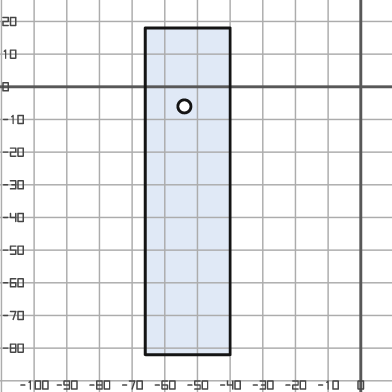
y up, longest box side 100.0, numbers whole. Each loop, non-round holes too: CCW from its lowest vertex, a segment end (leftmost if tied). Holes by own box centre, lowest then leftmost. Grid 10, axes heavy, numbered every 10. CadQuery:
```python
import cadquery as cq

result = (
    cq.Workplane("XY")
    .moveTo(-66.0, -82.0)
    .lineTo(-40.0, -82.0)
    .lineTo(-40.0, 18.0)
    .lineTo(-66.0, 18.0)
    .close()
    .moveTo(-54.0, -6.0)
    .circle(2.0)
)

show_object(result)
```